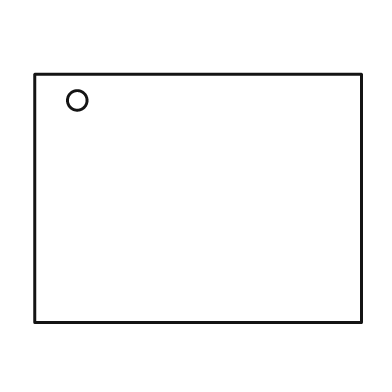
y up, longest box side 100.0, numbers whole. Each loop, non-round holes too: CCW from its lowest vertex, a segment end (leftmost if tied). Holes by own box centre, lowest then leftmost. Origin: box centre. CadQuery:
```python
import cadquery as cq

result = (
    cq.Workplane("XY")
    .moveTo(-50.0, -38.0)
    .lineTo(50.0, -38.0)
    .lineTo(50.0, 38.0)
    .lineTo(-50.0, 38.0)
    .close()
    .moveTo(-37.0, 30.0)
    .circle(3.0)
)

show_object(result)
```